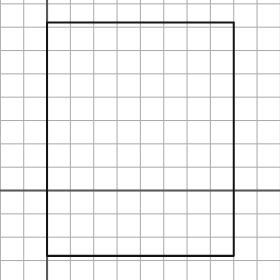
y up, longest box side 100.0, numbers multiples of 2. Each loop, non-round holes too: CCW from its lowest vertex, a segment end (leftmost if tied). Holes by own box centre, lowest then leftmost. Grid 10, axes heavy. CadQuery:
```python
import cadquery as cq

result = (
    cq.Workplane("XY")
    .moveTo(0.0, -28.0)
    .lineTo(80.0, -28.0)
    .lineTo(80.0, 72.0)
    .lineTo(0.0, 72.0)
    .close()
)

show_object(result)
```